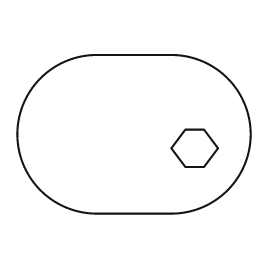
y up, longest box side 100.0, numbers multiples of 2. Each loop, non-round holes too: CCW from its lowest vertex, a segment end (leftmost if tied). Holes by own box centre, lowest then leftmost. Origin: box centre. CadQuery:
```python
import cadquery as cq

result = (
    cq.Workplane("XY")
    .moveTo(-16.0, -34.0)
    .lineTo(16.0, -34.0)
    .threePointArc((50.0, 0.0), (16.0, 34.0))
    .lineTo(-16.0, 34.0)
    .threePointArc((-50.0, 0.0), (-16.0, -34.0))
    .close()
    .moveTo(22.0, -14.0)
    .lineTo(30.0, -14.0)
    .lineTo(36.0, -6.0)
    .lineTo(30.0, 2.0)
    .lineTo(22.0, 2.0)
    .lineTo(16.0, -6.0)
    .close()
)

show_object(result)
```